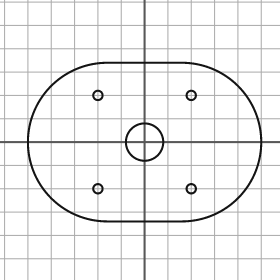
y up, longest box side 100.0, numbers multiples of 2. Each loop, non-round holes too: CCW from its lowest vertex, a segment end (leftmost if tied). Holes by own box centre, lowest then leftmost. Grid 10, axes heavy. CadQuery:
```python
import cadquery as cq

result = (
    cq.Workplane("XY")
    .moveTo(-16.0, -34.0)
    .lineTo(16.0, -34.0)
    .threePointArc((50.0, 0.0), (16.0, 34.0))
    .lineTo(-16.0, 34.0)
    .threePointArc((-50.0, 0.0), (-16.0, -34.0))
    .close()
    .moveTo(-20.0, -20.0)
    .circle(2.0)
    .moveTo(20.0, -20.0)
    .circle(2.0)
    .moveTo(0.0, 0.0)
    .circle(8.0)
    .moveTo(-20.0, 20.0)
    .circle(2.0)
    .moveTo(20.0, 20.0)
    .circle(2.0)
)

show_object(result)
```